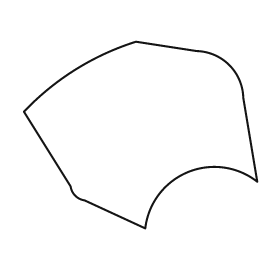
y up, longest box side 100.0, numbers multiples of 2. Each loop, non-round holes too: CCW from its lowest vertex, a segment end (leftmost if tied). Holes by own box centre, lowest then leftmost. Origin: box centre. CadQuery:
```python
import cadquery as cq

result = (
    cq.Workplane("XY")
    .moveTo(2.0, -40.0)
    .threePointArc((20.0, -16.0), (50.0, -20.0))
    .lineTo(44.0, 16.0)
    .threePointArc((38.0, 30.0), (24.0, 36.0))
    .lineTo(-2.0, 40.0)
    .threePointArc((-28.0, 28.0), (-50.0, 10.0))
    .lineTo(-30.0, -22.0)
    .threePointArc((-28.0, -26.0), (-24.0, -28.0))
    .close()
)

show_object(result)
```